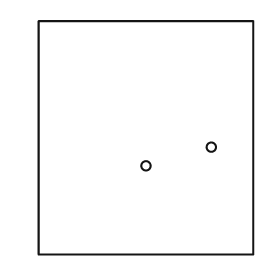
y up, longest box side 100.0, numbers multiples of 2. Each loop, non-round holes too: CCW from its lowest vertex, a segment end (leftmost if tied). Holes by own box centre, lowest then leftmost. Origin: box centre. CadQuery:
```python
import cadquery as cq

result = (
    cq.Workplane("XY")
    .moveTo(-46.0, -50.0)
    .lineTo(46.0, -50.0)
    .lineTo(46.0, 50.0)
    .lineTo(-46.0, 50.0)
    .close()
    .moveTo(0.0, -12.0)
    .circle(2.0)
    .moveTo(28.0, -4.0)
    .circle(2.0)
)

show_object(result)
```